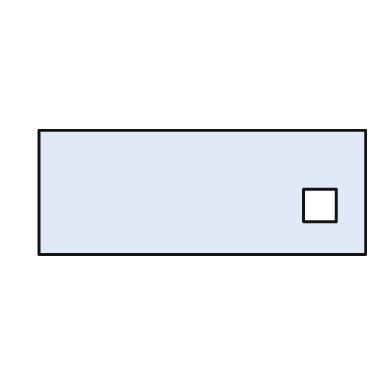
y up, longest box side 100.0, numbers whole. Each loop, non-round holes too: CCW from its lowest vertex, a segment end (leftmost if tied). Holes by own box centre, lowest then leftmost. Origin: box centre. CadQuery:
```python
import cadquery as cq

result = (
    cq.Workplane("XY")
    .moveTo(-50.0, -19.0)
    .lineTo(50.0, -19.0)
    .lineTo(50.0, 19.0)
    .lineTo(-50.0, 19.0)
    .close()
    .moveTo(31.0, -9.0)
    .lineTo(41.0, -9.0)
    .lineTo(41.0, 1.0)
    .lineTo(31.0, 1.0)
    .close()
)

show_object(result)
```